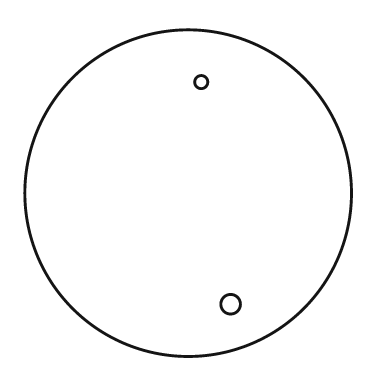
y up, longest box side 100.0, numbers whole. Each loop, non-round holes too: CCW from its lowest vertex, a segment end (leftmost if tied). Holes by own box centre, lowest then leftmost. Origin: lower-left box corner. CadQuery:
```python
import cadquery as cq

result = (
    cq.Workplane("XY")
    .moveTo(50.0, 50.0)
    .circle(50.0)
    .moveTo(63.0, 16.0)
    .circle(3.0)
    .moveTo(54.0, 84.0)
    .circle(2.0)
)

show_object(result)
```